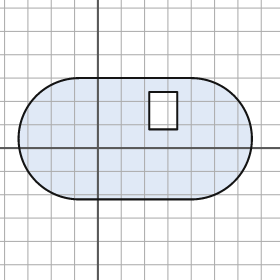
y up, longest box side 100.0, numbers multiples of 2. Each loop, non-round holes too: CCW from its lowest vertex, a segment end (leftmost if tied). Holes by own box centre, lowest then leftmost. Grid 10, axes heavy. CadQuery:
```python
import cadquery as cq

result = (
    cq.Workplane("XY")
    .moveTo(-8.0, -22.0)
    .lineTo(40.0, -22.0)
    .threePointArc((66.0, 4.0), (40.0, 30.0))
    .lineTo(-8.0, 30.0)
    .threePointArc((-34.0, 4.0), (-8.0, -22.0))
    .close()
    .moveTo(22.0, 8.0)
    .lineTo(34.0, 8.0)
    .lineTo(34.0, 24.0)
    .lineTo(22.0, 24.0)
    .close()
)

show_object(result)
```